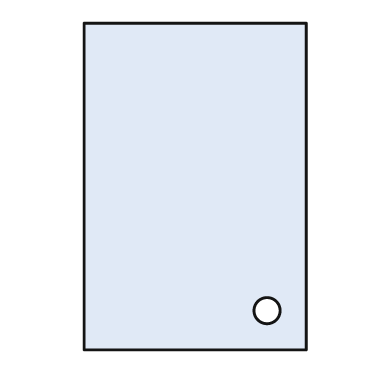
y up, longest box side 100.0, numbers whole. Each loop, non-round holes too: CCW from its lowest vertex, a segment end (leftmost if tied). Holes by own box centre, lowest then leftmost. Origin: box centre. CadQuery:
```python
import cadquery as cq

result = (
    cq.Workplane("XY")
    .moveTo(-34.0, -50.0)
    .lineTo(34.0, -50.0)
    .lineTo(34.0, 50.0)
    .lineTo(-34.0, 50.0)
    .close()
    .moveTo(22.0, -38.0)
    .circle(4.0)
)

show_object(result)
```